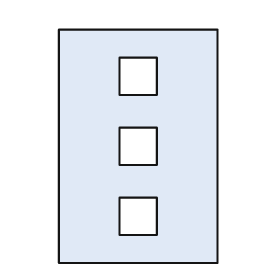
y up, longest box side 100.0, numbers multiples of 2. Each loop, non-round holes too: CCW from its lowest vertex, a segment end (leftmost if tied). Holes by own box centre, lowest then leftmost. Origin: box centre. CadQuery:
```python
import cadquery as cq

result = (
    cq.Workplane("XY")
    .moveTo(-34.0, -50.0)
    .lineTo(34.0, -50.0)
    .lineTo(34.0, 50.0)
    .lineTo(-34.0, 50.0)
    .close()
    .moveTo(-8.0, -38.0)
    .lineTo(8.0, -38.0)
    .lineTo(8.0, -22.0)
    .lineTo(-8.0, -22.0)
    .close()
    .moveTo(-8.0, -8.0)
    .lineTo(8.0, -8.0)
    .lineTo(8.0, 8.0)
    .lineTo(-8.0, 8.0)
    .close()
    .moveTo(-8.0, 22.0)
    .lineTo(8.0, 22.0)
    .lineTo(8.0, 38.0)
    .lineTo(-8.0, 38.0)
    .close()
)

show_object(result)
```